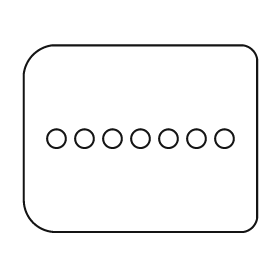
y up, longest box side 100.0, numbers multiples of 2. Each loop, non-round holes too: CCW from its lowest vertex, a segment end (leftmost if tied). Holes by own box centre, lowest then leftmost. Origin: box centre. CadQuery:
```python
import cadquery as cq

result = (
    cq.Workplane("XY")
    .moveTo(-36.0, -40.0)
    .lineTo(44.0, -40.0)
    .threePointArc((48.0, -38.0), (50.0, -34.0))
    .lineTo(50.0, 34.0)
    .threePointArc((48.0, 38.0), (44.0, 40.0))
    .lineTo(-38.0, 40.0)
    .threePointArc((-46.0, 36.0), (-50.0, 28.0))
    .lineTo(-50.0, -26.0)
    .threePointArc((-46.0, -36.0), (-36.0, -40.0))
    .close()
    .moveTo(-36.0, 0.0)
    .circle(4.0)
    .moveTo(-24.0, 0.0)
    .circle(4.0)
    .moveTo(-12.0, 0.0)
    .circle(4.0)
    .moveTo(0.0, 0.0)
    .circle(4.0)
    .moveTo(12.0, 0.0)
    .circle(4.0)
    .moveTo(24.0, 0.0)
    .circle(4.0)
    .moveTo(36.0, 0.0)
    .circle(4.0)
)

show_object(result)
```